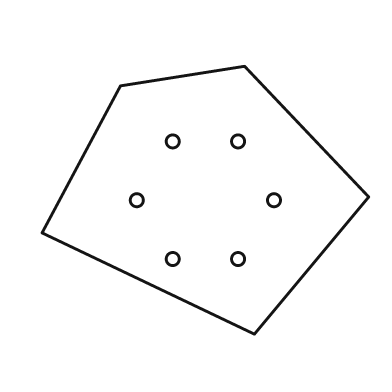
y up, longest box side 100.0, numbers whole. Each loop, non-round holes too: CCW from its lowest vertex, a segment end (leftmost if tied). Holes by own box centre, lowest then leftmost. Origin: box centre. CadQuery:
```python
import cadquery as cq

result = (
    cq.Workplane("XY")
    .moveTo(15.0, -41.0)
    .lineTo(50.0, 1.0)
    .lineTo(12.0, 41.0)
    .lineTo(-26.0, 35.0)
    .lineTo(-50.0, -10.0)
    .close()
    .moveTo(-10.0, -18.0)
    .circle(2.0)
    .moveTo(10.0, -18.0)
    .circle(2.0)
    .moveTo(-21.0, 0.0)
    .circle(2.0)
    .moveTo(21.0, 0.0)
    .circle(2.0)
    .moveTo(-10.0, 18.0)
    .circle(2.0)
    .moveTo(10.0, 18.0)
    .circle(2.0)
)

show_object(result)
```